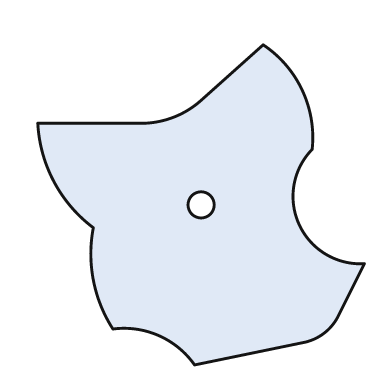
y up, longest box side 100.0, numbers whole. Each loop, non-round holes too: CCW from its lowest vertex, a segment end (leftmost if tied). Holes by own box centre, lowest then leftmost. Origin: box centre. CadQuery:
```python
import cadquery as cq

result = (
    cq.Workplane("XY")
    .moveTo(-2.0, -49.0)
    .lineTo(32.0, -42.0)
    .threePointArc((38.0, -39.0), (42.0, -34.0))
    .lineTo(50.0, -18.0)
    .threePointArc((30.0, -6.0), (34.0, 17.0))
    .threePointArc((31.0, 35.0), (19.0, 49.0))
    .lineTo(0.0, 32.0)
    .threePointArc((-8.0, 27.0), (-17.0, 25.0))
    .lineTo(-50.0, 25.0)
    .threePointArc((-45.0, 7.0), (-33.0, -7.0))
    .threePointArc((-33.0, -23.0), (-27.0, -38.0))
    .threePointArc((-13.0, -40.0), (-2.0, -49.0))
    .close()
    .moveTo(0.0, 0.0)
    .circle(4.0)
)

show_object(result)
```